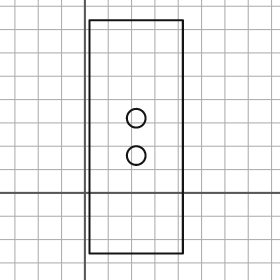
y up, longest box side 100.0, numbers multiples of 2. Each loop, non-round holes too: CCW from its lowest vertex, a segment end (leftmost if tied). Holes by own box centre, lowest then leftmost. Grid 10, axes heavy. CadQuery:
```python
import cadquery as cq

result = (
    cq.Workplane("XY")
    .moveTo(2.0, -26.0)
    .lineTo(42.0, -26.0)
    .lineTo(42.0, 74.0)
    .lineTo(2.0, 74.0)
    .close()
    .moveTo(22.0, 16.0)
    .circle(4.0)
    .moveTo(22.0, 32.0)
    .circle(4.0)
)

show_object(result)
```